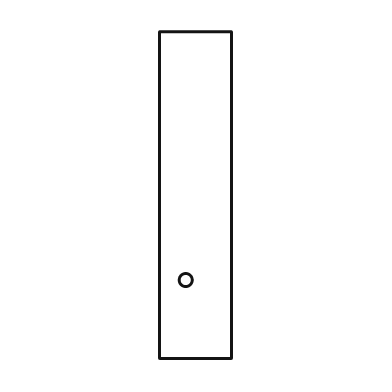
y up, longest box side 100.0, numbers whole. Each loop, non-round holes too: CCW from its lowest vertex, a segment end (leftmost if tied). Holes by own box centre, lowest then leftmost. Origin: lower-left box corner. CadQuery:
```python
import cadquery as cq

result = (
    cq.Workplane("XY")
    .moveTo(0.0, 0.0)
    .lineTo(22.0, 0.0)
    .lineTo(22.0, 100.0)
    .lineTo(0.0, 100.0)
    .close()
    .moveTo(8.0, 24.0)
    .circle(2.0)
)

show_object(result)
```